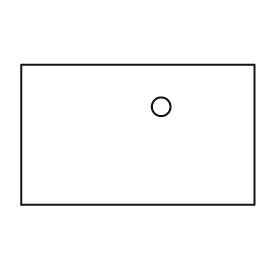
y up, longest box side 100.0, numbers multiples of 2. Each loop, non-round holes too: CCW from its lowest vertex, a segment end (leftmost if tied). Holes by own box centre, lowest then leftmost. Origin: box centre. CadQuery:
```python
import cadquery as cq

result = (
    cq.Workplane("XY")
    .moveTo(-50.0, -30.0)
    .lineTo(50.0, -30.0)
    .lineTo(50.0, 30.0)
    .lineTo(-50.0, 30.0)
    .close()
    .moveTo(10.0, 12.0)
    .circle(4.0)
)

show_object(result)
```